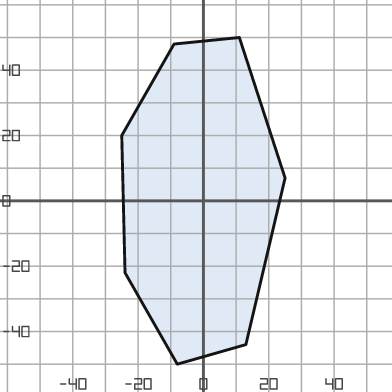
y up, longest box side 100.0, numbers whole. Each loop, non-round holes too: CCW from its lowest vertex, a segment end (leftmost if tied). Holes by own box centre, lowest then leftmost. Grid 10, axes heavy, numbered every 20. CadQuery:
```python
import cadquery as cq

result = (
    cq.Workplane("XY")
    .moveTo(-8.0, -50.0)
    .lineTo(13.0, -44.0)
    .lineTo(25.0, 7.0)
    .lineTo(11.0, 50.0)
    .lineTo(-9.0, 48.0)
    .lineTo(-25.0, 20.0)
    .lineTo(-24.0, -22.0)
    .close()
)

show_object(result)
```